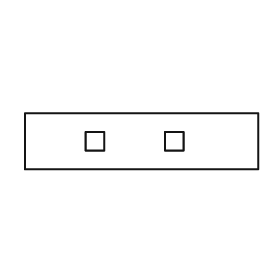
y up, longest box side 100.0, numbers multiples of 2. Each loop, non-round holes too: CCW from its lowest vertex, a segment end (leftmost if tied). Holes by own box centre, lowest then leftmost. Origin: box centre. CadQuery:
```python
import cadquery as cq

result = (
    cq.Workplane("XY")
    .moveTo(-50.0, -12.0)
    .lineTo(50.0, -12.0)
    .lineTo(50.0, 12.0)
    .lineTo(-50.0, 12.0)
    .close()
    .moveTo(-24.0, -4.0)
    .lineTo(-16.0, -4.0)
    .lineTo(-16.0, 4.0)
    .lineTo(-24.0, 4.0)
    .close()
    .moveTo(10.0, -4.0)
    .lineTo(18.0, -4.0)
    .lineTo(18.0, 4.0)
    .lineTo(10.0, 4.0)
    .close()
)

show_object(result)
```